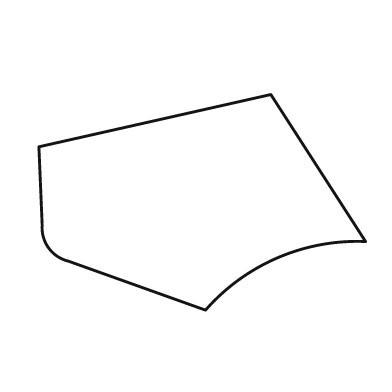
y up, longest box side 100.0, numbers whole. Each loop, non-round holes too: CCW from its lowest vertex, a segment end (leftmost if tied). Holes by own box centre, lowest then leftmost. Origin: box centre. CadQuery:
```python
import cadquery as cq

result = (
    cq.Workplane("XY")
    .moveTo(1.0, -33.0)
    .threePointArc((23.0, -17.0), (50.0, -12.0))
    .lineTo(21.0, 33.0)
    .lineTo(-50.0, 17.0)
    .lineTo(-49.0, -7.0)
    .threePointArc((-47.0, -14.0), (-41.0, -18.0))
    .close()
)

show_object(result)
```